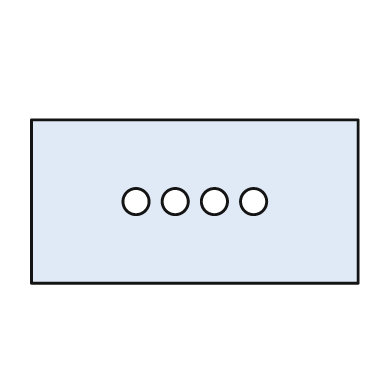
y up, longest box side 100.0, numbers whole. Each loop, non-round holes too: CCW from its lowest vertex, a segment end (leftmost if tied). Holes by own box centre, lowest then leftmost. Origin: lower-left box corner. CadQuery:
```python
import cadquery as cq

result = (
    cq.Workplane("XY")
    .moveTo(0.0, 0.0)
    .lineTo(100.0, 0.0)
    .lineTo(100.0, 50.0)
    .lineTo(0.0, 50.0)
    .close()
    .moveTo(32.0, 25.0)
    .circle(4.0)
    .moveTo(44.0, 25.0)
    .circle(4.0)
    .moveTo(56.0, 25.0)
    .circle(4.0)
    .moveTo(68.0, 25.0)
    .circle(4.0)
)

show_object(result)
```